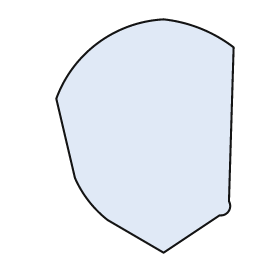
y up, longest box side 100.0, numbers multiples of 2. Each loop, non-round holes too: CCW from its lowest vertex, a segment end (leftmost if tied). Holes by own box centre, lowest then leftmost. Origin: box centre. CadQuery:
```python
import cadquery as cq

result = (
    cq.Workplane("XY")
    .moveTo(8.0, -50.0)
    .lineTo(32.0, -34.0)
    .threePointArc((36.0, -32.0), (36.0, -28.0))
    .lineTo(38.0, 38.0)
    .threePointArc((24.0, 46.0), (8.0, 50.0))
    .threePointArc((-20.0, 40.0), (-38.0, 16.0))
    .lineTo(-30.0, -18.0)
    .threePointArc((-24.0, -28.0), (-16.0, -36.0))
    .close()
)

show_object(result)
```